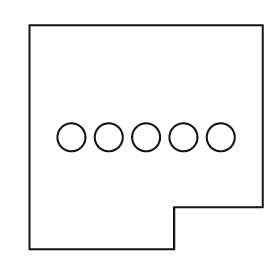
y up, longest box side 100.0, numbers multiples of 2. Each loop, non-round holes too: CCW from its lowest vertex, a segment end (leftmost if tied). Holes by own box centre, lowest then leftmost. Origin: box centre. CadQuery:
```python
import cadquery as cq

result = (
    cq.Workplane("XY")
    .moveTo(-50.0, -48.0)
    .lineTo(12.0, -48.0)
    .lineTo(12.0, -30.0)
    .lineTo(50.0, -30.0)
    .lineTo(50.0, 48.0)
    .lineTo(-50.0, 48.0)
    .close()
    .moveTo(-32.0, 0.0)
    .circle(6.0)
    .moveTo(-16.0, 0.0)
    .circle(6.0)
    .moveTo(0.0, 0.0)
    .circle(6.0)
    .moveTo(16.0, 0.0)
    .circle(6.0)
    .moveTo(32.0, 0.0)
    .circle(6.0)
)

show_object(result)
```